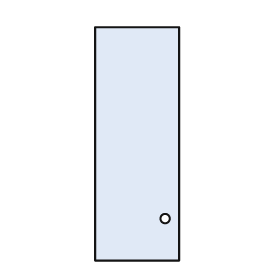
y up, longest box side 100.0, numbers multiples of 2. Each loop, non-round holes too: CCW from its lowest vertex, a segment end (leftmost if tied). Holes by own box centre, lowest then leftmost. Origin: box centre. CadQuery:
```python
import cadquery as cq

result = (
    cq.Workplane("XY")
    .moveTo(-18.0, -50.0)
    .lineTo(18.0, -50.0)
    .lineTo(18.0, 50.0)
    .lineTo(-18.0, 50.0)
    .close()
    .moveTo(12.0, -32.0)
    .circle(2.0)
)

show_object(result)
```